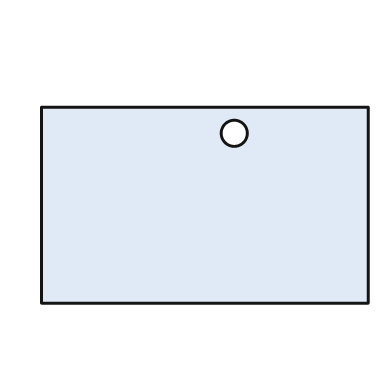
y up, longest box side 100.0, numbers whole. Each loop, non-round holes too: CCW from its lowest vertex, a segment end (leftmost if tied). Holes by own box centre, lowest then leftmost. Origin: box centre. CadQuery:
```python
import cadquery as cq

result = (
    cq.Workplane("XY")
    .moveTo(-50.0, -30.0)
    .lineTo(50.0, -30.0)
    .lineTo(50.0, 30.0)
    .lineTo(-50.0, 30.0)
    .close()
    .moveTo(9.0, 22.0)
    .circle(4.0)
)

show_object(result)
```